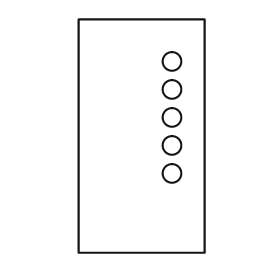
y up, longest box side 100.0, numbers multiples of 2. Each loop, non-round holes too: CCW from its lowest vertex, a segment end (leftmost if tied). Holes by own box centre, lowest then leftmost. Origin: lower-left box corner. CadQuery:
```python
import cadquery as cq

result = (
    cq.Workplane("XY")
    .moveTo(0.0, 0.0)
    .lineTo(54.0, 0.0)
    .lineTo(54.0, 100.0)
    .lineTo(0.0, 100.0)
    .close()
    .moveTo(40.0, 34.0)
    .circle(4.0)
    .moveTo(40.0, 46.0)
    .circle(4.0)
    .moveTo(40.0, 58.0)
    .circle(4.0)
    .moveTo(40.0, 70.0)
    .circle(4.0)
    .moveTo(40.0, 82.0)
    .circle(4.0)
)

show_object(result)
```